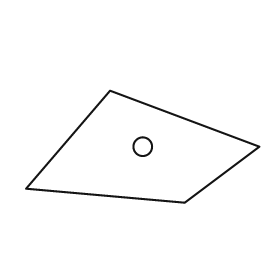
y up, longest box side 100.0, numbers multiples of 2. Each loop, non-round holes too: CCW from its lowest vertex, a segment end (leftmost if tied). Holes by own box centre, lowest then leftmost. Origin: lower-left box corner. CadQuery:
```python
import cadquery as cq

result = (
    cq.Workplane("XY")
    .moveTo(68.0, 0.0)
    .lineTo(100.0, 24.0)
    .lineTo(36.0, 48.0)
    .lineTo(0.0, 6.0)
    .close()
    .moveTo(50.0, 24.0)
    .circle(4.0)
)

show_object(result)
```